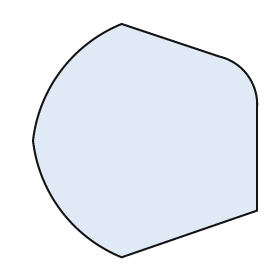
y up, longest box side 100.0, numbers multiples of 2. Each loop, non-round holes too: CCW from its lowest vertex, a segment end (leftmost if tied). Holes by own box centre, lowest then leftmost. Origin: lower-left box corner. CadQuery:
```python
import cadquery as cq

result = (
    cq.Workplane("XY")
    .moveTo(38.0, 0.0)
    .lineTo(96.0, 20.0)
    .lineTo(96.0, 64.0)
    .threePointArc((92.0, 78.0), (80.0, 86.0))
    .lineTo(38.0, 100.0)
    .threePointArc((12.0, 80.0), (0.0, 50.0))
    .threePointArc((12.0, 20.0), (38.0, 0.0))
    .close()
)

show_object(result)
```